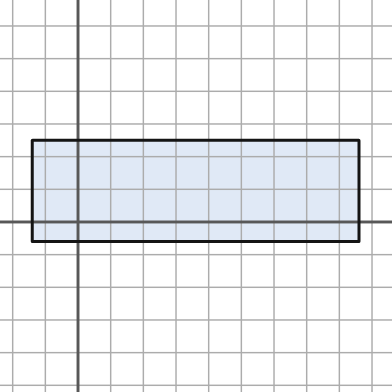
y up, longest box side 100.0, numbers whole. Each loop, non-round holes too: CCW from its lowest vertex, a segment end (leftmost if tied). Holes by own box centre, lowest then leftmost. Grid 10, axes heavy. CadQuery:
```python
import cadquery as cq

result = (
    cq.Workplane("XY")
    .moveTo(-14.0, -6.0)
    .lineTo(86.0, -6.0)
    .lineTo(86.0, 25.0)
    .lineTo(-14.0, 25.0)
    .close()
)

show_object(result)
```